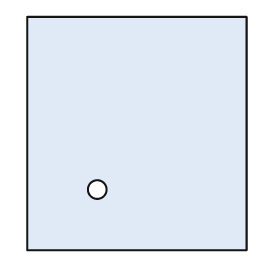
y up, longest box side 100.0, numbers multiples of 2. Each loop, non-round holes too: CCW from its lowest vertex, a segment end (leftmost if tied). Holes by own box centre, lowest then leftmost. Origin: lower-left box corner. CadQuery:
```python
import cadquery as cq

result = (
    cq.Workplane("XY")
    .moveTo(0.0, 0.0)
    .lineTo(94.0, 0.0)
    .lineTo(94.0, 100.0)
    .lineTo(0.0, 100.0)
    .close()
    .moveTo(30.0, 26.0)
    .circle(4.0)
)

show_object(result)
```